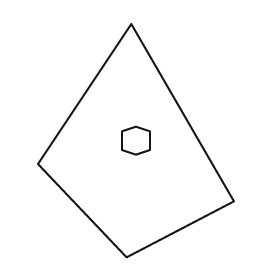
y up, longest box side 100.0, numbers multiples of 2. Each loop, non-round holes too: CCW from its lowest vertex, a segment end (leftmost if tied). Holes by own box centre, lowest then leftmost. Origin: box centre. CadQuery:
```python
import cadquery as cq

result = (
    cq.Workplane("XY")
    .moveTo(-4.0, -50.0)
    .lineTo(42.0, -26.0)
    .lineTo(-2.0, 50.0)
    .lineTo(-42.0, -10.0)
    .close()
    .moveTo(0.0, -6.0)
    .lineTo(6.0, -4.0)
    .lineTo(6.0, 4.0)
    .lineTo(0.0, 6.0)
    .lineTo(-6.0, 4.0)
    .lineTo(-6.0, -4.0)
    .close()
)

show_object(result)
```